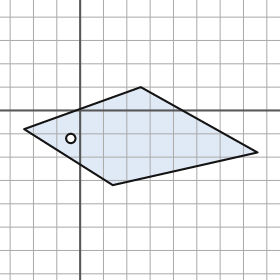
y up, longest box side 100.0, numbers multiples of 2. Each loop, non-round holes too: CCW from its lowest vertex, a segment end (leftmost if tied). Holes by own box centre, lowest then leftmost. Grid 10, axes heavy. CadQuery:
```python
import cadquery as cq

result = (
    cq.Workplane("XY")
    .moveTo(14.0, -32.0)
    .lineTo(76.0, -18.0)
    .lineTo(26.0, 10.0)
    .lineTo(-24.0, -8.0)
    .close()
    .moveTo(-4.0, -12.0)
    .circle(2.0)
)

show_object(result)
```